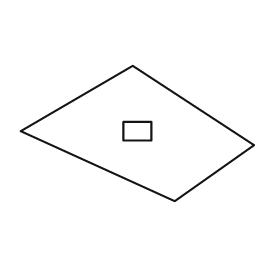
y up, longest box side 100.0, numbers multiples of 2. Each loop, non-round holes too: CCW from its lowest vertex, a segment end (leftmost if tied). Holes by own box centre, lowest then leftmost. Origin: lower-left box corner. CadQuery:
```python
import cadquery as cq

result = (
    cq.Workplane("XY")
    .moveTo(66.0, 0.0)
    .lineTo(100.0, 24.0)
    .lineTo(48.0, 58.0)
    .lineTo(0.0, 30.0)
    .close()
    .moveTo(44.0, 26.0)
    .lineTo(56.0, 26.0)
    .lineTo(56.0, 34.0)
    .lineTo(44.0, 34.0)
    .close()
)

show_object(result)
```